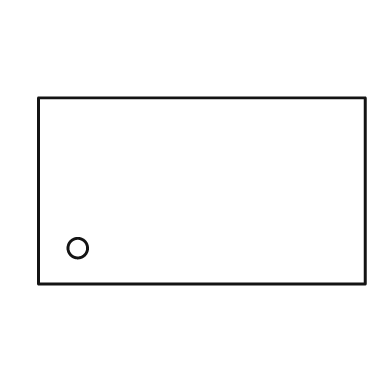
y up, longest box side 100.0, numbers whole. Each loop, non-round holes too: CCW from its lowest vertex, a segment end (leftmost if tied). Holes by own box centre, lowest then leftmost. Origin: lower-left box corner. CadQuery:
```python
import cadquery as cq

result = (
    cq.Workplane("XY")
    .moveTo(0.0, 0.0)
    .lineTo(100.0, 0.0)
    .lineTo(100.0, 57.0)
    .lineTo(0.0, 57.0)
    .close()
    .moveTo(12.0, 11.0)
    .circle(3.0)
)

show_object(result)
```